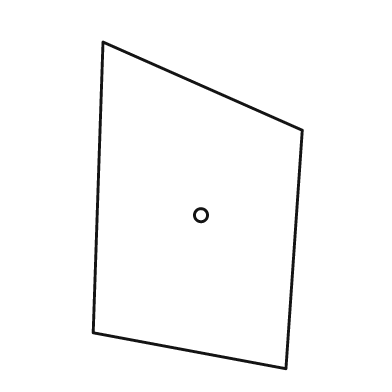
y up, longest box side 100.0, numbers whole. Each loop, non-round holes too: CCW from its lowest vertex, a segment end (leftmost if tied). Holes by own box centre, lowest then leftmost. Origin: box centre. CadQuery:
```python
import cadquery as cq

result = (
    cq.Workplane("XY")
    .moveTo(27.0, -50.0)
    .lineTo(32.0, 23.0)
    .lineTo(-29.0, 50.0)
    .lineTo(-32.0, -39.0)
    .close()
    .moveTo(1.0, -3.0)
    .circle(2.0)
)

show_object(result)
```